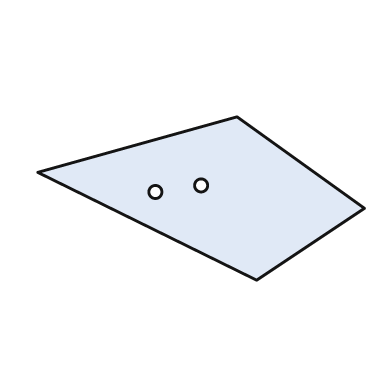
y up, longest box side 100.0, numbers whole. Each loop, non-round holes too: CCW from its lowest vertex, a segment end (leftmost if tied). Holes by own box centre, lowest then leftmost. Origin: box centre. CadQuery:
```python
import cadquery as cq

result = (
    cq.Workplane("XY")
    .moveTo(17.0, -25.0)
    .lineTo(50.0, -3.0)
    .lineTo(11.0, 25.0)
    .lineTo(-50.0, 8.0)
    .close()
    .moveTo(-14.0, 2.0)
    .circle(2.0)
    .moveTo(0.0, 4.0)
    .circle(2.0)
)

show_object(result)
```